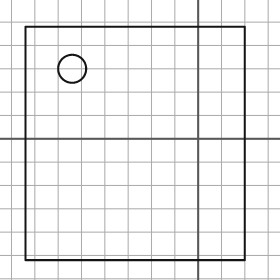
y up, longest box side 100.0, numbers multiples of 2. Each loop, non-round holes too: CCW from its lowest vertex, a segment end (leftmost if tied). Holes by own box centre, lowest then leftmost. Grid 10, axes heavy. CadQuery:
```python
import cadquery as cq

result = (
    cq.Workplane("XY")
    .moveTo(-74.0, -52.0)
    .lineTo(20.0, -52.0)
    .lineTo(20.0, 48.0)
    .lineTo(-74.0, 48.0)
    .close()
    .moveTo(-54.0, 30.0)
    .circle(6.0)
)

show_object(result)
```